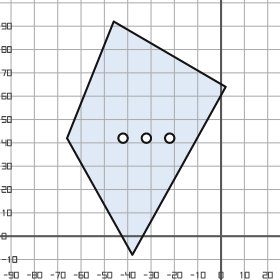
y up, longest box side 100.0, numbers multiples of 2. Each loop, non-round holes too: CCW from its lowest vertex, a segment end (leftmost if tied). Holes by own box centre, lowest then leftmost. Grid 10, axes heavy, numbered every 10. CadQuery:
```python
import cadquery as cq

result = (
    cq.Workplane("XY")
    .moveTo(-38.0, -8.0)
    .lineTo(2.0, 64.0)
    .lineTo(-46.0, 92.0)
    .lineTo(-66.0, 42.0)
    .close()
    .moveTo(-42.0, 42.0)
    .circle(2.0)
    .moveTo(-32.0, 42.0)
    .circle(2.0)
    .moveTo(-22.0, 42.0)
    .circle(2.0)
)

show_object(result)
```